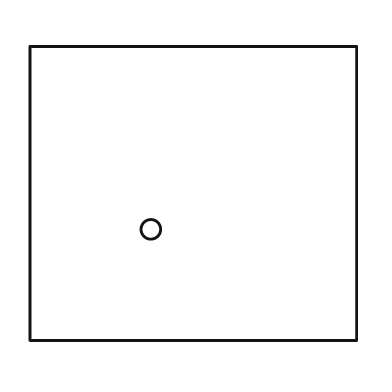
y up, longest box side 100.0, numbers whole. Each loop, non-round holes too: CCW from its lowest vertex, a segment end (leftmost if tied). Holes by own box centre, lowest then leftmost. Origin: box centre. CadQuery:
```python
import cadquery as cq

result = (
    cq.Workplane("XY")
    .moveTo(-50.0, -45.0)
    .lineTo(50.0, -45.0)
    .lineTo(50.0, 45.0)
    .lineTo(-50.0, 45.0)
    .close()
    .moveTo(-13.0, -11.0)
    .circle(3.0)
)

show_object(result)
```